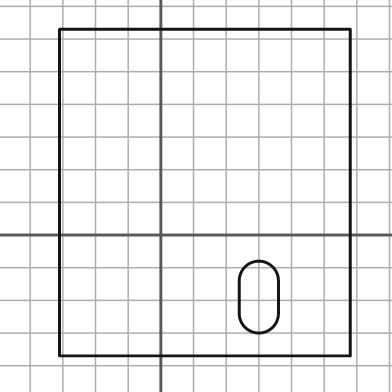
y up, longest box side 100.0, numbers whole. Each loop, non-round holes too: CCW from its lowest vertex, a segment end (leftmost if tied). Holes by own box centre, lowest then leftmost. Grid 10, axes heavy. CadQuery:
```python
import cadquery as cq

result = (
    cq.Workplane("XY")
    .moveTo(-31.0, -37.0)
    .lineTo(58.0, -37.0)
    .lineTo(58.0, 63.0)
    .lineTo(-31.0, 63.0)
    .close()
    .moveTo(24.0, -24.0)
    .threePointArc((30.0, -30.0), (36.0, -24.0))
    .lineTo(36.0, -14.0)
    .threePointArc((30.0, -8.0), (24.0, -14.0))
    .close()
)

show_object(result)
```